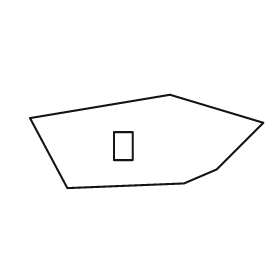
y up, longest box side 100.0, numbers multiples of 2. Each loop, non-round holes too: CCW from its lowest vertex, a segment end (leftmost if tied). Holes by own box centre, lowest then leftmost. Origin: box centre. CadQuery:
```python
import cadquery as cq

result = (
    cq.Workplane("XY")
    .moveTo(-34.0, -20.0)
    .lineTo(16.0, -18.0)
    .lineTo(30.0, -12.0)
    .lineTo(50.0, 8.0)
    .lineTo(10.0, 20.0)
    .lineTo(-50.0, 10.0)
    .close()
    .moveTo(-14.0, -8.0)
    .lineTo(-6.0, -8.0)
    .lineTo(-6.0, 4.0)
    .lineTo(-14.0, 4.0)
    .close()
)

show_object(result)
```